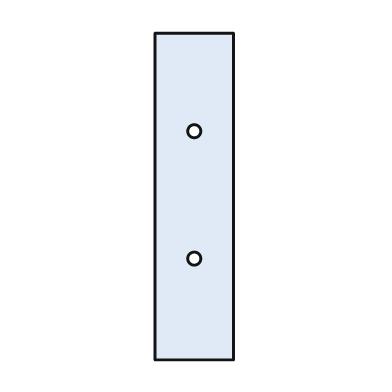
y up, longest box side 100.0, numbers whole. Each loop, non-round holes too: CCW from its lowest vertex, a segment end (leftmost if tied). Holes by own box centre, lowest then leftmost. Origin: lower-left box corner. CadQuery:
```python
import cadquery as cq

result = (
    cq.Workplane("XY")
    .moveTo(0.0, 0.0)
    .lineTo(24.0, 0.0)
    .lineTo(24.0, 100.0)
    .lineTo(0.0, 100.0)
    .close()
    .moveTo(12.0, 31.0)
    .circle(2.0)
    .moveTo(12.0, 70.0)
    .circle(2.0)
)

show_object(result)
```